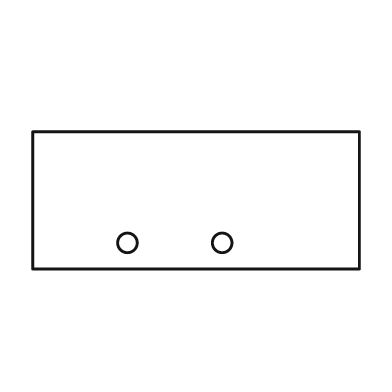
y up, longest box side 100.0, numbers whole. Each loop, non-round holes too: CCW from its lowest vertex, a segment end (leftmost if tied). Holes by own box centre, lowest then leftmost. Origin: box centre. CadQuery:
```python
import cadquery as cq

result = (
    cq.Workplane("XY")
    .moveTo(-50.0, -21.0)
    .lineTo(50.0, -21.0)
    .lineTo(50.0, 21.0)
    .lineTo(-50.0, 21.0)
    .close()
    .moveTo(-21.0, -13.0)
    .circle(3.0)
    .moveTo(8.0, -13.0)
    .circle(3.0)
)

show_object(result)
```